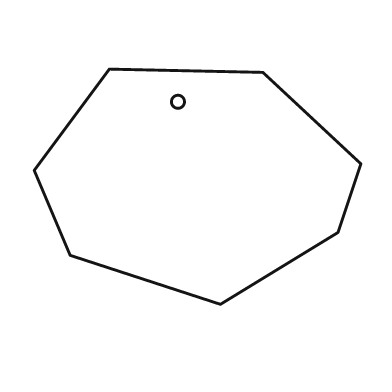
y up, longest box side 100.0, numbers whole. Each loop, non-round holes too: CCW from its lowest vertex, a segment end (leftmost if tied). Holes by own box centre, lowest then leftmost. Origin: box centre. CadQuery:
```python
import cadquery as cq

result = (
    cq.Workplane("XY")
    .moveTo(7.0, -36.0)
    .lineTo(43.0, -14.0)
    .lineTo(50.0, 7.0)
    .lineTo(20.0, 35.0)
    .lineTo(-27.0, 36.0)
    .lineTo(-50.0, 5.0)
    .lineTo(-39.0, -21.0)
    .close()
    .moveTo(-6.0, 26.0)
    .circle(2.0)
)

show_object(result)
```